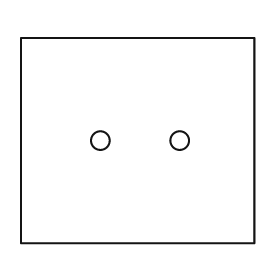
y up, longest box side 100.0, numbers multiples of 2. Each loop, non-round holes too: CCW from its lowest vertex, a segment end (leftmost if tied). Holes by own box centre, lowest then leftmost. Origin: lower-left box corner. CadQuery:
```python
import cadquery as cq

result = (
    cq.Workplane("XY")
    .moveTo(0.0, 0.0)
    .lineTo(100.0, 0.0)
    .lineTo(100.0, 88.0)
    .lineTo(0.0, 88.0)
    .close()
    .moveTo(34.0, 44.0)
    .circle(4.0)
    .moveTo(68.0, 44.0)
    .circle(4.0)
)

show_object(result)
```